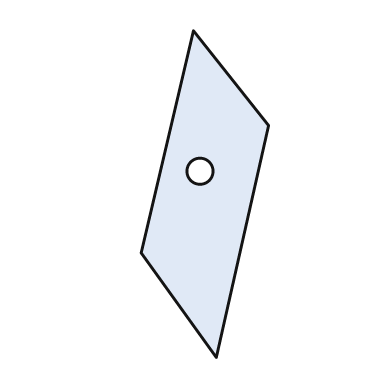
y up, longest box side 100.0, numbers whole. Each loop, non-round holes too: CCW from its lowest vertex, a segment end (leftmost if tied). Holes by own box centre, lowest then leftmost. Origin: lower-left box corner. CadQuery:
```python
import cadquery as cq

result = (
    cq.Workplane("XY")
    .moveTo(23.0, 0.0)
    .lineTo(39.0, 71.0)
    .lineTo(16.0, 100.0)
    .lineTo(0.0, 32.0)
    .close()
    .moveTo(18.0, 57.0)
    .circle(4.0)
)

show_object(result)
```